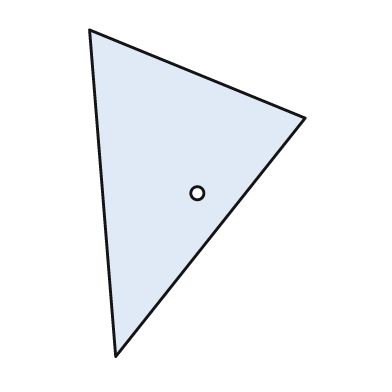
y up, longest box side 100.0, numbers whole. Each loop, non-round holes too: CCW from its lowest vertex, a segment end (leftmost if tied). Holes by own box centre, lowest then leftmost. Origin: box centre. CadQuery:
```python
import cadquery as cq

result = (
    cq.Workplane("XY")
    .moveTo(-25.0, -50.0)
    .lineTo(33.0, 23.0)
    .lineTo(-33.0, 50.0)
    .close()
    .moveTo(0.0, 0.0)
    .circle(2.0)
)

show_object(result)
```